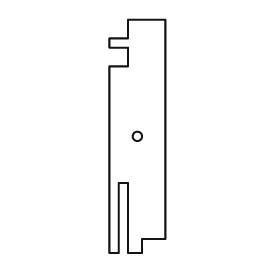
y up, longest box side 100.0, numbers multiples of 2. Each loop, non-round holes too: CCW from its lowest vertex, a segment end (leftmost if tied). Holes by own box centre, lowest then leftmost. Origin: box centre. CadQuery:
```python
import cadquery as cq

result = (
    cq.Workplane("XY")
    .moveTo(-12.0, -50.0)
    .lineTo(-8.0, -50.0)
    .lineTo(-8.0, -20.0)
    .lineTo(-4.0, -20.0)
    .lineTo(-4.0, -50.0)
    .lineTo(2.0, -50.0)
    .lineTo(2.0, -44.0)
    .lineTo(12.0, -44.0)
    .lineTo(12.0, 50.0)
    .lineTo(-4.0, 50.0)
    .lineTo(-4.0, 42.0)
    .lineTo(-12.0, 42.0)
    .lineTo(-12.0, 38.0)
    .lineTo(-4.0, 38.0)
    .lineTo(-4.0, 30.0)
    .lineTo(-12.0, 30.0)
    .close()
    .moveTo(0.0, 0.0)
    .circle(2.0)
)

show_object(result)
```